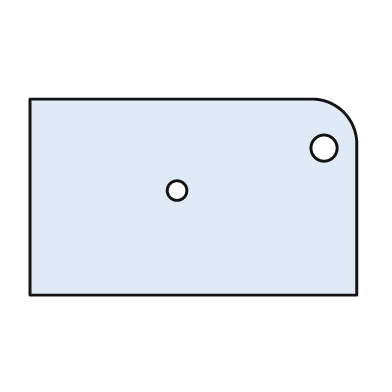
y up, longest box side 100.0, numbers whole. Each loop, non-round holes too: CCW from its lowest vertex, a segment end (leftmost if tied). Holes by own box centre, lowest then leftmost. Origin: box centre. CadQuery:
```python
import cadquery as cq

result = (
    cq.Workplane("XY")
    .moveTo(-50.0, -30.0)
    .lineTo(50.0, -30.0)
    .lineTo(50.0, 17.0)
    .threePointArc((46.0, 26.0), (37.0, 30.0))
    .lineTo(-50.0, 30.0)
    .close()
    .moveTo(-5.0, 2.0)
    .circle(3.0)
    .moveTo(40.0, 15.0)
    .circle(4.0)
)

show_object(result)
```